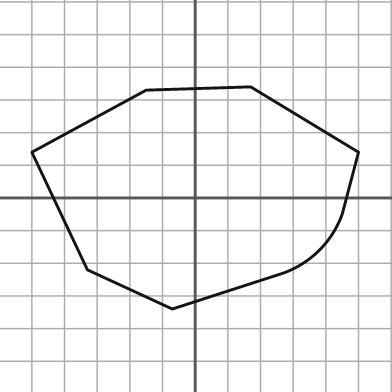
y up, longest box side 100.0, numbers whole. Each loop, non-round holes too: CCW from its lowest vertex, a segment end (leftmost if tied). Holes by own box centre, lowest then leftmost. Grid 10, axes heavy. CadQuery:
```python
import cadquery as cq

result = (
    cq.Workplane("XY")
    .moveTo(-7.0, -34.0)
    .lineTo(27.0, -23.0)
    .threePointArc((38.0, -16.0), (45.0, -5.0))
    .lineTo(50.0, 14.0)
    .lineTo(17.0, 34.0)
    .lineTo(-15.0, 33.0)
    .lineTo(-50.0, 14.0)
    .lineTo(-33.0, -22.0)
    .close()
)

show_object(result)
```